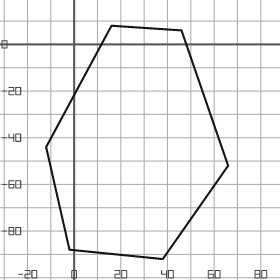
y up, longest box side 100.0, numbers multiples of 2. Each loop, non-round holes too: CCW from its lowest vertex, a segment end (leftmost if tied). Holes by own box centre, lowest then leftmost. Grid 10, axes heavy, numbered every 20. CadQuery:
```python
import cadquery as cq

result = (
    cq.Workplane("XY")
    .moveTo(38.0, -92.0)
    .lineTo(66.0, -52.0)
    .lineTo(46.0, 6.0)
    .lineTo(16.0, 8.0)
    .lineTo(-12.0, -44.0)
    .lineTo(-2.0, -88.0)
    .close()
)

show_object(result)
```